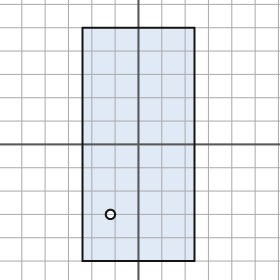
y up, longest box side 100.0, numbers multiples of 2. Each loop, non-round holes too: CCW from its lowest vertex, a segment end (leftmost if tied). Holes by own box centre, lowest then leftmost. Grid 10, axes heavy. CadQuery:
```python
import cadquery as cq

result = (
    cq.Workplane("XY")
    .moveTo(-24.0, -50.0)
    .lineTo(24.0, -50.0)
    .lineTo(24.0, 50.0)
    .lineTo(-24.0, 50.0)
    .close()
    .moveTo(-12.0, -30.0)
    .circle(2.0)
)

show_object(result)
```